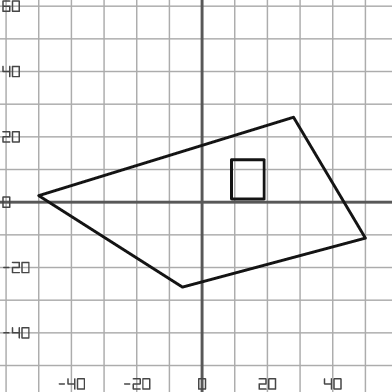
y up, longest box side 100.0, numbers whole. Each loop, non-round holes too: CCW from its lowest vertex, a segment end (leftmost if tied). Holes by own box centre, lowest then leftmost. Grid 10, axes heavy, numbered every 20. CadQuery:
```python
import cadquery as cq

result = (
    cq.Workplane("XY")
    .moveTo(-6.0, -26.0)
    .lineTo(50.0, -11.0)
    .lineTo(28.0, 26.0)
    .lineTo(-50.0, 2.0)
    .close()
    .moveTo(9.0, 1.0)
    .lineTo(19.0, 1.0)
    .lineTo(19.0, 13.0)
    .lineTo(9.0, 13.0)
    .close()
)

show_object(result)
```